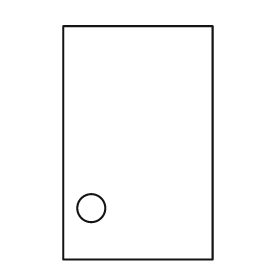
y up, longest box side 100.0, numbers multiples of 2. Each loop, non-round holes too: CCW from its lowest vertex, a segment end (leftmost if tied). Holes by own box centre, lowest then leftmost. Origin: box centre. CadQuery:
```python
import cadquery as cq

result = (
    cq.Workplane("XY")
    .moveTo(-32.0, -50.0)
    .lineTo(32.0, -50.0)
    .lineTo(32.0, 50.0)
    .lineTo(-32.0, 50.0)
    .close()
    .moveTo(-20.0, -28.0)
    .circle(6.0)
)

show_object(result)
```